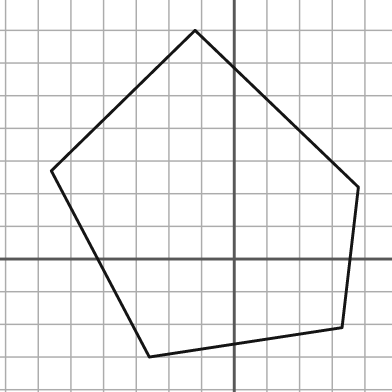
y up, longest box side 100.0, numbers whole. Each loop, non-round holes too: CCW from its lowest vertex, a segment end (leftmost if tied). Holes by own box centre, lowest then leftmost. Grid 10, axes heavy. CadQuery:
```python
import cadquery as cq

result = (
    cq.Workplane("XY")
    .moveTo(-26.0, -30.0)
    .lineTo(33.0, -21.0)
    .lineTo(38.0, 22.0)
    .lineTo(-12.0, 70.0)
    .lineTo(-56.0, 27.0)
    .close()
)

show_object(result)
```